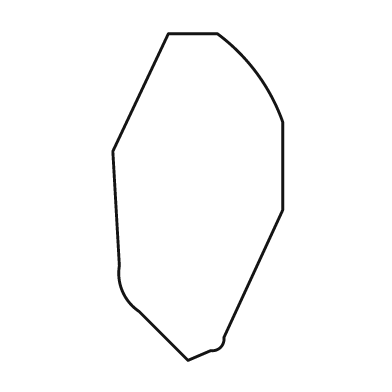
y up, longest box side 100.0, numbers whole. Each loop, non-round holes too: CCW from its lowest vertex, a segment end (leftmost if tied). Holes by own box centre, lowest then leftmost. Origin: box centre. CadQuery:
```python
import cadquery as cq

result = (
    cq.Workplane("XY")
    .moveTo(-3.0, -50.0)
    .lineTo(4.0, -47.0)
    .threePointArc((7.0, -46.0), (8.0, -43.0))
    .lineTo(26.0, -4.0)
    .lineTo(26.0, 23.0)
    .threePointArc((18.0, 38.0), (6.0, 50.0))
    .lineTo(-9.0, 50.0)
    .lineTo(-26.0, 14.0)
    .lineTo(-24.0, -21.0)
    .threePointArc((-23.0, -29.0), (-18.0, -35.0))
    .close()
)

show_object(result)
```